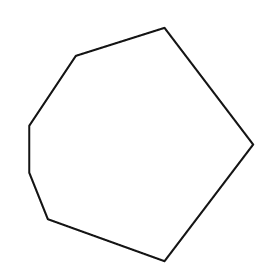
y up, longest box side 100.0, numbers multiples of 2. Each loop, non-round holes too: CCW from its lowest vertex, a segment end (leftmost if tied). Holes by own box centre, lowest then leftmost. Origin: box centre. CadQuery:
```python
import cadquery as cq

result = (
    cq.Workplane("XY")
    .moveTo(10.0, -50.0)
    .lineTo(48.0, 0.0)
    .lineTo(10.0, 50.0)
    .lineTo(-28.0, 38.0)
    .lineTo(-48.0, 8.0)
    .lineTo(-48.0, -12.0)
    .lineTo(-40.0, -32.0)
    .close()
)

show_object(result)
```